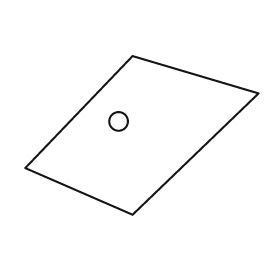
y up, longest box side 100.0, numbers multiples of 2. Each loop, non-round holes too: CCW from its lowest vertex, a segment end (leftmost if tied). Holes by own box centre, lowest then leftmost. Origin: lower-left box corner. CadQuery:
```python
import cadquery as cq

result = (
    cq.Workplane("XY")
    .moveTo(46.0, 0.0)
    .lineTo(100.0, 52.0)
    .lineTo(46.0, 68.0)
    .lineTo(0.0, 20.0)
    .close()
    .moveTo(40.0, 40.0)
    .circle(4.0)
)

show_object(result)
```